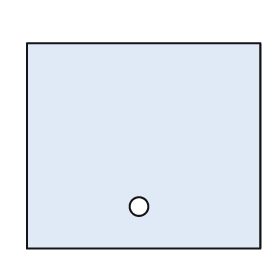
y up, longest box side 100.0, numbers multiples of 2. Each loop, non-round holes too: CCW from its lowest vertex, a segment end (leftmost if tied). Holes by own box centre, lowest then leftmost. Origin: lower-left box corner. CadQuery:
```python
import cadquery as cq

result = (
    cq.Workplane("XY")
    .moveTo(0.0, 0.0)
    .lineTo(100.0, 0.0)
    .lineTo(100.0, 88.0)
    .lineTo(0.0, 88.0)
    .close()
    .moveTo(48.0, 18.0)
    .circle(4.0)
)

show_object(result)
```